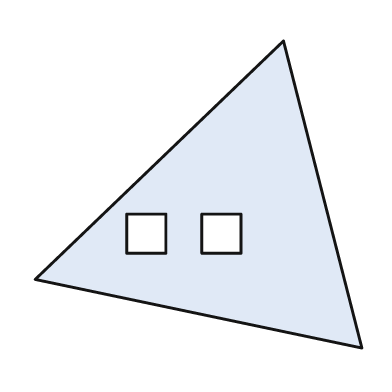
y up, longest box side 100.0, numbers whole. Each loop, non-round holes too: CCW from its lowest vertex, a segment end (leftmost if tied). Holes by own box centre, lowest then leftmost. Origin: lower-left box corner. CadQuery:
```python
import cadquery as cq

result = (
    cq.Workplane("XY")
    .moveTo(100.0, 0.0)
    .lineTo(76.0, 94.0)
    .lineTo(0.0, 21.0)
    .close()
    .moveTo(28.0, 29.0)
    .lineTo(40.0, 29.0)
    .lineTo(40.0, 41.0)
    .lineTo(28.0, 41.0)
    .close()
    .moveTo(51.0, 29.0)
    .lineTo(63.0, 29.0)
    .lineTo(63.0, 41.0)
    .lineTo(51.0, 41.0)
    .close()
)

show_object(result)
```